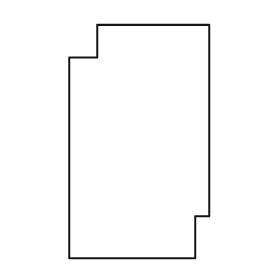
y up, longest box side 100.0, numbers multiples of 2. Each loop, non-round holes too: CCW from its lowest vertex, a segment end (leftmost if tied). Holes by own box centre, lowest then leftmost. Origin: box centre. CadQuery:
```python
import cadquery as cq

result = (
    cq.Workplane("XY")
    .moveTo(-30.0, -50.0)
    .lineTo(24.0, -50.0)
    .lineTo(24.0, -32.0)
    .lineTo(30.0, -32.0)
    .lineTo(30.0, 50.0)
    .lineTo(-18.0, 50.0)
    .lineTo(-18.0, 36.0)
    .lineTo(-30.0, 36.0)
    .close()
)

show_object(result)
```